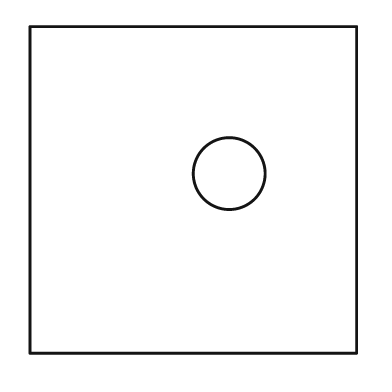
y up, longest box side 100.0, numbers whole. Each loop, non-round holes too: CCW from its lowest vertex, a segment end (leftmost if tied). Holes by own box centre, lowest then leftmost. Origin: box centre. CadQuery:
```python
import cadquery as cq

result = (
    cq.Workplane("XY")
    .moveTo(-50.0, -50.0)
    .lineTo(50.0, -50.0)
    .lineTo(50.0, 50.0)
    .lineTo(-50.0, 50.0)
    .close()
    .moveTo(11.0, 5.0)
    .circle(11.0)
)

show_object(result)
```